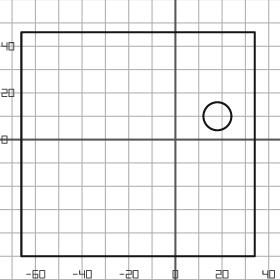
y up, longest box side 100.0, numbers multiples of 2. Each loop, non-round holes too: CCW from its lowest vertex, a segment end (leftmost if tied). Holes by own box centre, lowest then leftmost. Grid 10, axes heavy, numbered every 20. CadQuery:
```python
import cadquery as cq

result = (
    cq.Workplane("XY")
    .moveTo(-66.0, -50.0)
    .lineTo(34.0, -50.0)
    .lineTo(34.0, 46.0)
    .lineTo(-66.0, 46.0)
    .close()
    .moveTo(18.0, 10.0)
    .circle(6.0)
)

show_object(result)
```